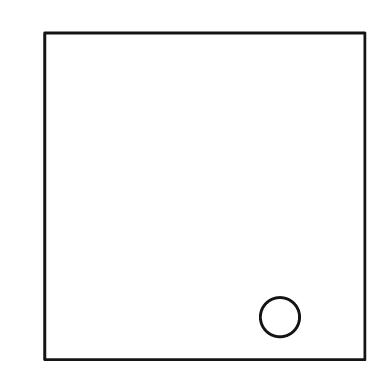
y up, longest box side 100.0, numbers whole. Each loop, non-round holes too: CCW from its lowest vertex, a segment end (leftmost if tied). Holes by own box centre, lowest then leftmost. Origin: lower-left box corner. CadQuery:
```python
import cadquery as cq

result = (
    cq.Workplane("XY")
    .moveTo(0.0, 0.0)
    .lineTo(98.0, 0.0)
    .lineTo(98.0, 100.0)
    .lineTo(0.0, 100.0)
    .close()
    .moveTo(72.0, 13.0)
    .circle(6.0)
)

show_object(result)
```